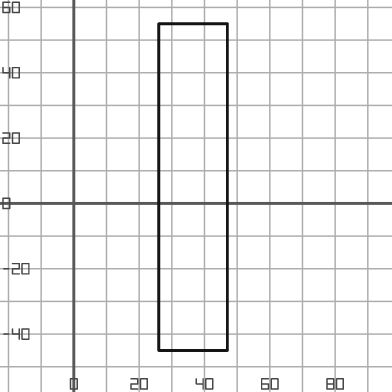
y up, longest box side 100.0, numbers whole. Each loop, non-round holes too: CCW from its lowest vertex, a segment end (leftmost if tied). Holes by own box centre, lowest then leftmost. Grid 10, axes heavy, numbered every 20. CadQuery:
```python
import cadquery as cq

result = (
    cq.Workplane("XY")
    .moveTo(26.0, -45.0)
    .lineTo(47.0, -45.0)
    .lineTo(47.0, 55.0)
    .lineTo(26.0, 55.0)
    .close()
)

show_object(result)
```